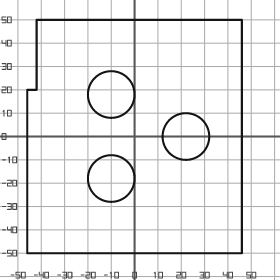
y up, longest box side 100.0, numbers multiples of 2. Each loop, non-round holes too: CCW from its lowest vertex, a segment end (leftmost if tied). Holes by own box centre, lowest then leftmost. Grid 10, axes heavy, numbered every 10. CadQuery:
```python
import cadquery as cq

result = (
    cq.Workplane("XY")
    .moveTo(-46.0, -50.0)
    .lineTo(46.0, -50.0)
    .lineTo(46.0, 50.0)
    .lineTo(-42.0, 50.0)
    .lineTo(-42.0, 20.0)
    .lineTo(-46.0, 20.0)
    .close()
    .moveTo(-10.0, -18.0)
    .circle(10.0)
    .moveTo(22.0, 0.0)
    .circle(10.0)
    .moveTo(-10.0, 18.0)
    .circle(10.0)
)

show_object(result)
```